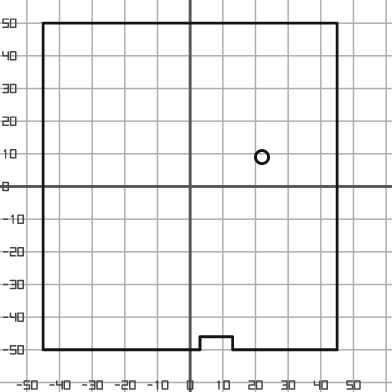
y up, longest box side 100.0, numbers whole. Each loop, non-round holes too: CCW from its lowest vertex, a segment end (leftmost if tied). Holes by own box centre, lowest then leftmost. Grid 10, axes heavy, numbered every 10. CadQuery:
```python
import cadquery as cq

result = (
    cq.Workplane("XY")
    .moveTo(-45.0, -50.0)
    .lineTo(3.0, -50.0)
    .lineTo(3.0, -46.0)
    .lineTo(13.0, -46.0)
    .lineTo(13.0, -50.0)
    .lineTo(45.0, -50.0)
    .lineTo(45.0, 50.0)
    .lineTo(-45.0, 50.0)
    .close()
    .moveTo(22.0, 9.0)
    .circle(2.0)
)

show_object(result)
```